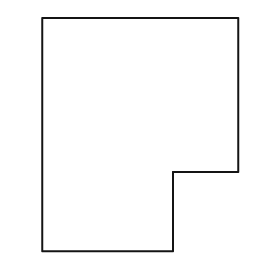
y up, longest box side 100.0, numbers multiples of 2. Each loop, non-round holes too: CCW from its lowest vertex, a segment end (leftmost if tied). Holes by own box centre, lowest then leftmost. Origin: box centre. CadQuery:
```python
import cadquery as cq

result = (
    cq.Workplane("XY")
    .moveTo(-42.0, -50.0)
    .lineTo(14.0, -50.0)
    .lineTo(14.0, -16.0)
    .lineTo(42.0, -16.0)
    .lineTo(42.0, 50.0)
    .lineTo(-42.0, 50.0)
    .close()
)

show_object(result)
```